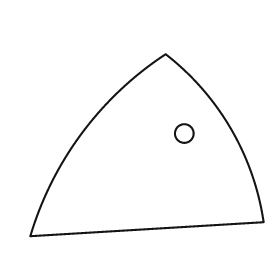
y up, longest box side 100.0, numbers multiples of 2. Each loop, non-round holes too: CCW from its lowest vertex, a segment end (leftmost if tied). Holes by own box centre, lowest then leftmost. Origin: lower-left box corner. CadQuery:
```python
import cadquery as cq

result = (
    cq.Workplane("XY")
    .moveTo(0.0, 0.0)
    .lineTo(100.0, 6.0)
    .threePointArc((86.0, 46.0), (58.0, 78.0))
    .threePointArc((22.0, 44.0), (0.0, 0.0))
    .close()
    .moveTo(66.0, 44.0)
    .circle(4.0)
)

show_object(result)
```